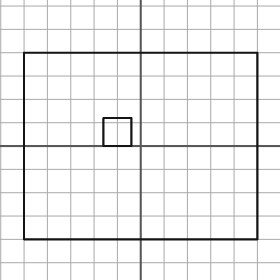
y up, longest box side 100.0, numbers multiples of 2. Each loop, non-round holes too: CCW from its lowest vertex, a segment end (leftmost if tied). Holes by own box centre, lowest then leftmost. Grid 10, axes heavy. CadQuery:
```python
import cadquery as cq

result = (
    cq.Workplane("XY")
    .moveTo(-50.0, -40.0)
    .lineTo(50.0, -40.0)
    .lineTo(50.0, 40.0)
    .lineTo(-50.0, 40.0)
    .close()
    .moveTo(-16.0, 0.0)
    .lineTo(-4.0, 0.0)
    .lineTo(-4.0, 12.0)
    .lineTo(-16.0, 12.0)
    .close()
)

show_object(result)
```